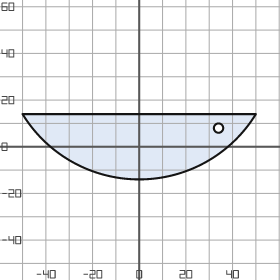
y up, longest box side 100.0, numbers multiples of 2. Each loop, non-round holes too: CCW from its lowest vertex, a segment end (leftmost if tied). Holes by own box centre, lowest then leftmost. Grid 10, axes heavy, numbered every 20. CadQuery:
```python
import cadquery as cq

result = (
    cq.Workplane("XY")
    .moveTo(-50.0, 14.0)
    .threePointArc((0.0, -14.0), (50.0, 14.0))
    .close()
    .moveTo(34.0, 8.0)
    .circle(2.0)
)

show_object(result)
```